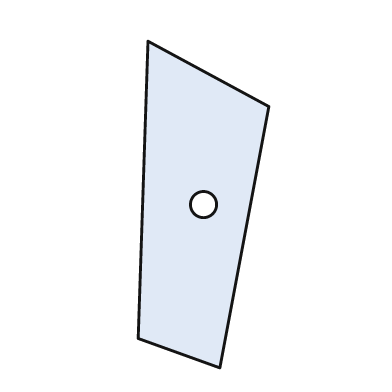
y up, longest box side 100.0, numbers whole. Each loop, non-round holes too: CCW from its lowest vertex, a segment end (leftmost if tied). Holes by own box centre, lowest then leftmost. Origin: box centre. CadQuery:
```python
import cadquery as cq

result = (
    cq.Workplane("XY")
    .moveTo(5.0, -50.0)
    .lineTo(20.0, 30.0)
    .lineTo(-17.0, 50.0)
    .lineTo(-20.0, -41.0)
    .close()
    .moveTo(0.0, 0.0)
    .circle(4.0)
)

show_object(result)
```